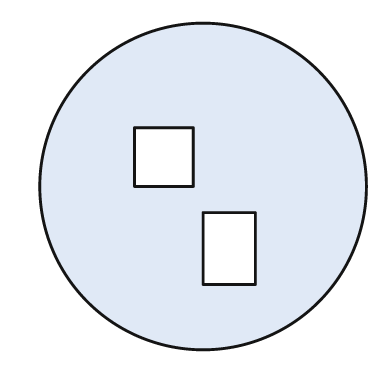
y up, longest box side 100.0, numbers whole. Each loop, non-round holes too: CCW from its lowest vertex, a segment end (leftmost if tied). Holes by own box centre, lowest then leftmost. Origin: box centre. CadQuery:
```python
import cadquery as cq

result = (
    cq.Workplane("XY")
    .moveTo(0.0, 0.0)
    .circle(50.0)
    .moveTo(0.0, -30.0)
    .lineTo(16.0, -30.0)
    .lineTo(16.0, -8.0)
    .lineTo(0.0, -8.0)
    .close()
    .moveTo(-21.0, 0.0)
    .lineTo(-3.0, 0.0)
    .lineTo(-3.0, 18.0)
    .lineTo(-21.0, 18.0)
    .close()
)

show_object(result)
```